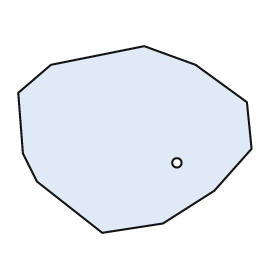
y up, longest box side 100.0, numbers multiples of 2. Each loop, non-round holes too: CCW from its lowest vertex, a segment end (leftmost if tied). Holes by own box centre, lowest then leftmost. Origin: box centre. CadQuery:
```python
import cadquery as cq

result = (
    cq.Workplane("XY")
    .moveTo(-14.0, -40.0)
    .lineTo(12.0, -36.0)
    .lineTo(34.0, -22.0)
    .lineTo(50.0, -4.0)
    .lineTo(48.0, 16.0)
    .lineTo(26.0, 32.0)
    .lineTo(4.0, 40.0)
    .lineTo(-36.0, 32.0)
    .lineTo(-50.0, 20.0)
    .lineTo(-48.0, -6.0)
    .lineTo(-42.0, -18.0)
    .close()
    .moveTo(18.0, -10.0)
    .circle(2.0)
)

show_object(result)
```